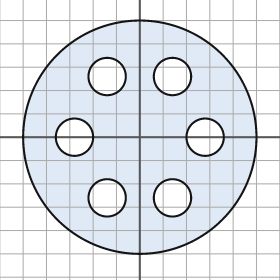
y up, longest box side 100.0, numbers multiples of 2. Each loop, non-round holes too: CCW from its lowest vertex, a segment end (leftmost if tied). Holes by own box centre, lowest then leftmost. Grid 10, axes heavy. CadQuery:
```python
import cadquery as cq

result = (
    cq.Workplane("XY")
    .moveTo(0.0, 0.0)
    .circle(50.0)
    .moveTo(-14.0, -26.0)
    .circle(8.0)
    .moveTo(14.0, -26.0)
    .circle(8.0)
    .moveTo(-28.0, 0.0)
    .circle(8.0)
    .moveTo(28.0, 0.0)
    .circle(8.0)
    .moveTo(-14.0, 26.0)
    .circle(8.0)
    .moveTo(14.0, 26.0)
    .circle(8.0)
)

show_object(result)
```